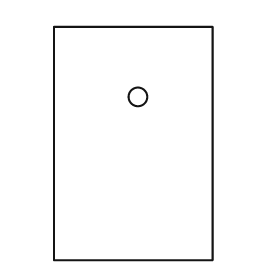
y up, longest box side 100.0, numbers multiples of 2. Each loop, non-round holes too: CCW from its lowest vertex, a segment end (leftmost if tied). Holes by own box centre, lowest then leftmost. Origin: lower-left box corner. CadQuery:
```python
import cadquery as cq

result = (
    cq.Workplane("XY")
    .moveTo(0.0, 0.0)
    .lineTo(68.0, 0.0)
    .lineTo(68.0, 100.0)
    .lineTo(0.0, 100.0)
    .close()
    .moveTo(36.0, 70.0)
    .circle(4.0)
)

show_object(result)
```